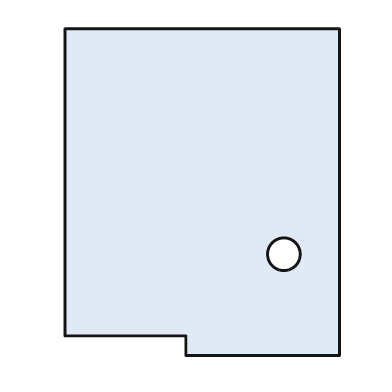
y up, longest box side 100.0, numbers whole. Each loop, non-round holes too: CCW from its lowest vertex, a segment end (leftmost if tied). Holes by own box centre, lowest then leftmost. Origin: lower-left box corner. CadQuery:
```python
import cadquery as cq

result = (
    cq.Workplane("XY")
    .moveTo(37.0, 0.0)
    .lineTo(84.0, 0.0)
    .lineTo(84.0, 100.0)
    .lineTo(0.0, 100.0)
    .lineTo(0.0, 6.0)
    .lineTo(37.0, 6.0)
    .close()
    .moveTo(67.0, 31.0)
    .circle(5.0)
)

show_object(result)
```